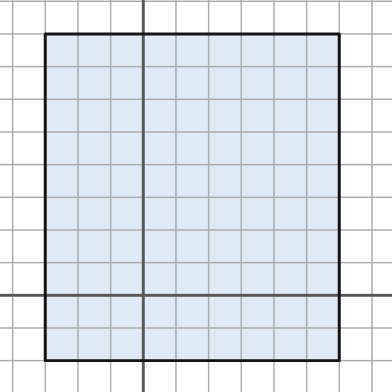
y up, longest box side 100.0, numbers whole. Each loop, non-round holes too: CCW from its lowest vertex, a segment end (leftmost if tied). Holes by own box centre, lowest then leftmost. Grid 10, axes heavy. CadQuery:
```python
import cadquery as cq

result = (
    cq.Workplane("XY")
    .moveTo(-30.0, -20.0)
    .lineTo(60.0, -20.0)
    .lineTo(60.0, 80.0)
    .lineTo(-30.0, 80.0)
    .close()
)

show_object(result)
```